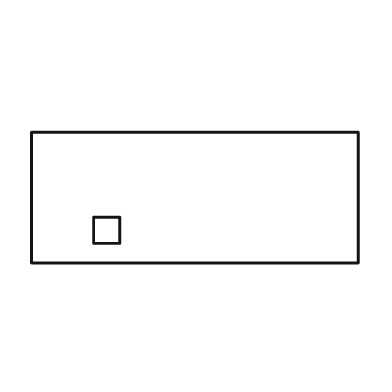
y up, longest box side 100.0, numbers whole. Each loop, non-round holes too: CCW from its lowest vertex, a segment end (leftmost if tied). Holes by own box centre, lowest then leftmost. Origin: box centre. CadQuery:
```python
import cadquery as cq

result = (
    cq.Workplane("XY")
    .moveTo(-50.0, -20.0)
    .lineTo(50.0, -20.0)
    .lineTo(50.0, 20.0)
    .lineTo(-50.0, 20.0)
    .close()
    .moveTo(-31.0, -14.0)
    .lineTo(-23.0, -14.0)
    .lineTo(-23.0, -6.0)
    .lineTo(-31.0, -6.0)
    .close()
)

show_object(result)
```